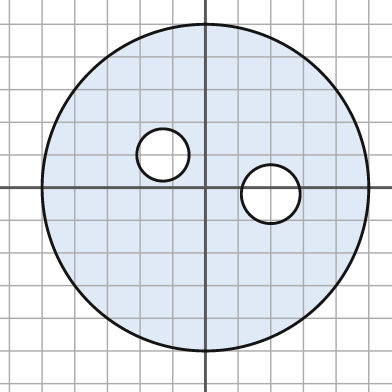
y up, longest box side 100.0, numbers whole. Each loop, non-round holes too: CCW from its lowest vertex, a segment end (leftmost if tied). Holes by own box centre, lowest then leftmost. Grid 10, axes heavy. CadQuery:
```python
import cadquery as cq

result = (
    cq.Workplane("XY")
    .moveTo(0.0, 0.0)
    .circle(50.0)
    .moveTo(20.0, -2.0)
    .circle(9.0)
    .moveTo(-13.0, 10.0)
    .circle(8.0)
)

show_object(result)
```